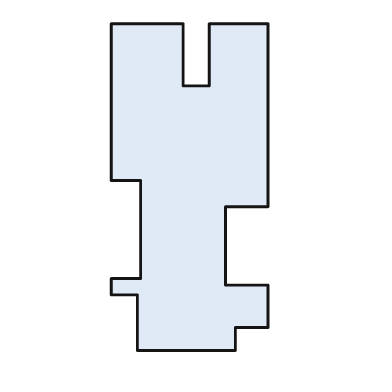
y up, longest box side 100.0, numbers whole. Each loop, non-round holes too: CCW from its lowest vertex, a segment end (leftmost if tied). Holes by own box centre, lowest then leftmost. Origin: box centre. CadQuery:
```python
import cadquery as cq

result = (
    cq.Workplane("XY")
    .moveTo(-16.0, -50.0)
    .lineTo(14.0, -50.0)
    .lineTo(14.0, -43.0)
    .lineTo(24.0, -43.0)
    .lineTo(24.0, -30.0)
    .lineTo(11.0, -30.0)
    .lineTo(11.0, -6.0)
    .lineTo(24.0, -6.0)
    .lineTo(24.0, 50.0)
    .lineTo(6.0, 50.0)
    .lineTo(6.0, 31.0)
    .lineTo(-2.0, 31.0)
    .lineTo(-2.0, 50.0)
    .lineTo(-24.0, 50.0)
    .lineTo(-24.0, 2.0)
    .lineTo(-15.0, 2.0)
    .lineTo(-15.0, -28.0)
    .lineTo(-24.0, -28.0)
    .lineTo(-24.0, -33.0)
    .lineTo(-16.0, -33.0)
    .close()
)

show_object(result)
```